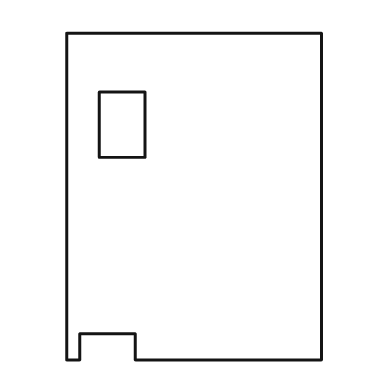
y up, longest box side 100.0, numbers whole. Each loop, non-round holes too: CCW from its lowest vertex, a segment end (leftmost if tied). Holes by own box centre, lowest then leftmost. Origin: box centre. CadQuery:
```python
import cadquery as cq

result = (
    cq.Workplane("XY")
    .moveTo(-39.0, -50.0)
    .lineTo(-35.0, -50.0)
    .lineTo(-35.0, -42.0)
    .lineTo(-18.0, -42.0)
    .lineTo(-18.0, -50.0)
    .lineTo(39.0, -50.0)
    .lineTo(39.0, 50.0)
    .lineTo(-39.0, 50.0)
    .close()
    .moveTo(-29.0, 12.0)
    .lineTo(-15.0, 12.0)
    .lineTo(-15.0, 32.0)
    .lineTo(-29.0, 32.0)
    .close()
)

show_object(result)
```